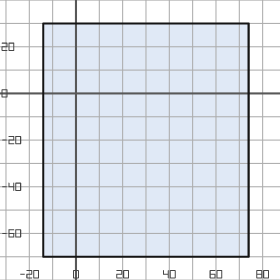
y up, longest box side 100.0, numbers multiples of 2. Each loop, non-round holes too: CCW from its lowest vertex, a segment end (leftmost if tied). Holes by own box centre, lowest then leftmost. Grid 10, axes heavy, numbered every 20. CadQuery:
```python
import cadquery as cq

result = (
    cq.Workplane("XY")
    .moveTo(-14.0, -70.0)
    .lineTo(74.0, -70.0)
    .lineTo(74.0, 30.0)
    .lineTo(-14.0, 30.0)
    .close()
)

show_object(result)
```